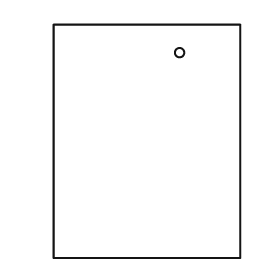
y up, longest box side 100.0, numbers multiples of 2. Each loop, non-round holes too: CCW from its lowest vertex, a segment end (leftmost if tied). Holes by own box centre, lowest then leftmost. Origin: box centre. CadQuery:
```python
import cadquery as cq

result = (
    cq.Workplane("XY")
    .moveTo(-40.0, -50.0)
    .lineTo(40.0, -50.0)
    .lineTo(40.0, 50.0)
    .lineTo(-40.0, 50.0)
    .close()
    .moveTo(14.0, 38.0)
    .circle(2.0)
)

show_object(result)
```